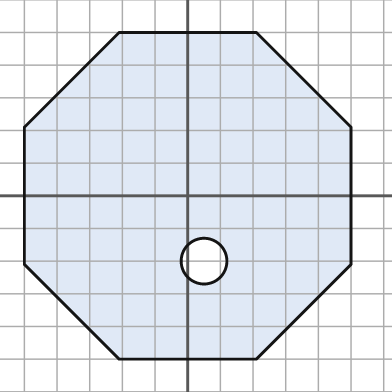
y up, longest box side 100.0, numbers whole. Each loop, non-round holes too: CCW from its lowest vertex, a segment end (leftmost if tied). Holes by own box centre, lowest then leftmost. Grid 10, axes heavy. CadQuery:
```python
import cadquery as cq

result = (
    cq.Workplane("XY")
    .moveTo(-21.0, -50.0)
    .lineTo(21.0, -50.0)
    .lineTo(50.0, -21.0)
    .lineTo(50.0, 21.0)
    .lineTo(21.0, 50.0)
    .lineTo(-21.0, 50.0)
    .lineTo(-50.0, 21.0)
    .lineTo(-50.0, -21.0)
    .close()
    .moveTo(5.0, -20.0)
    .circle(7.0)
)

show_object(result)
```